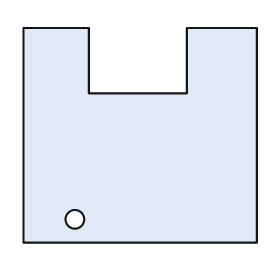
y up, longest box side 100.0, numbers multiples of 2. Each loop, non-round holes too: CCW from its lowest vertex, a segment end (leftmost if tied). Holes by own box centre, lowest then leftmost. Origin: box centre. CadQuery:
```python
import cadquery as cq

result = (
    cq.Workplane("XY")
    .moveTo(-50.0, -46.0)
    .lineTo(50.0, -46.0)
    .lineTo(50.0, 46.0)
    .lineTo(20.0, 46.0)
    .lineTo(20.0, 18.0)
    .lineTo(-22.0, 18.0)
    .lineTo(-22.0, 46.0)
    .lineTo(-50.0, 46.0)
    .close()
    .moveTo(-28.0, -36.0)
    .circle(4.0)
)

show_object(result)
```